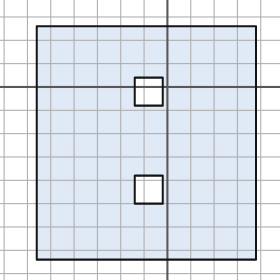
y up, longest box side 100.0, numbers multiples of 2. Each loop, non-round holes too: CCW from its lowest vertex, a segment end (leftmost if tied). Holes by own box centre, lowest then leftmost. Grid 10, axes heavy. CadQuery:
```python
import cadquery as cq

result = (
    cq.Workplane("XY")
    .moveTo(-56.0, -74.0)
    .lineTo(38.0, -74.0)
    .lineTo(38.0, 26.0)
    .lineTo(-56.0, 26.0)
    .close()
    .moveTo(-14.0, -50.0)
    .lineTo(-2.0, -50.0)
    .lineTo(-2.0, -38.0)
    .lineTo(-14.0, -38.0)
    .close()
    .moveTo(-14.0, -8.0)
    .lineTo(-2.0, -8.0)
    .lineTo(-2.0, 4.0)
    .lineTo(-14.0, 4.0)
    .close()
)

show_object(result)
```